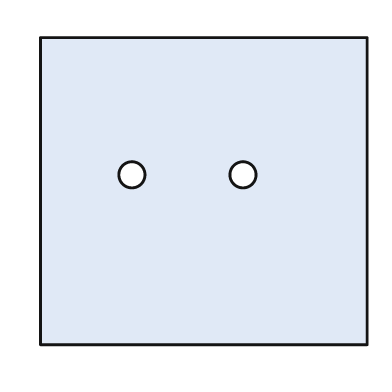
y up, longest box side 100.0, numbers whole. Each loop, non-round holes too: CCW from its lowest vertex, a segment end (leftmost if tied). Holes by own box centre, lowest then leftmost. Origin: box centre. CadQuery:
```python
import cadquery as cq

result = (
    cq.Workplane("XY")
    .moveTo(-50.0, -47.0)
    .lineTo(50.0, -47.0)
    .lineTo(50.0, 47.0)
    .lineTo(-50.0, 47.0)
    .close()
    .moveTo(-22.0, 5.0)
    .circle(4.0)
    .moveTo(12.0, 5.0)
    .circle(4.0)
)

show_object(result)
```